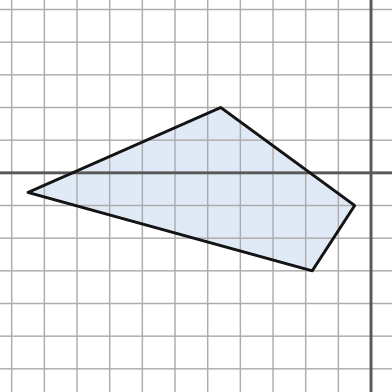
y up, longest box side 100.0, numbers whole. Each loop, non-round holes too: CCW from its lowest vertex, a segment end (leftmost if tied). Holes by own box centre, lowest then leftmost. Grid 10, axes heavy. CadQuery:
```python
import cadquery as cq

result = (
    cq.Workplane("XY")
    .moveTo(-18.0, -30.0)
    .lineTo(-5.0, -10.0)
    .lineTo(-46.0, 20.0)
    .lineTo(-105.0, -6.0)
    .close()
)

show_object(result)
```